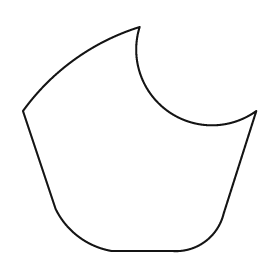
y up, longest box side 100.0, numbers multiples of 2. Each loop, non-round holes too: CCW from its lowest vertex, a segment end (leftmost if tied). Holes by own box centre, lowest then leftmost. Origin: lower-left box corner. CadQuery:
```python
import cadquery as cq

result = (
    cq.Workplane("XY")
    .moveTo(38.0, 0.0)
    .lineTo(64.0, 0.0)
    .threePointArc((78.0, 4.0), (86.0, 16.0))
    .lineTo(100.0, 60.0)
    .threePointArc((62.0, 60.0), (50.0, 96.0))
    .threePointArc((22.0, 82.0), (0.0, 60.0))
    .lineTo(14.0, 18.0)
    .threePointArc((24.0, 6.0), (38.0, 0.0))
    .close()
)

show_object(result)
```